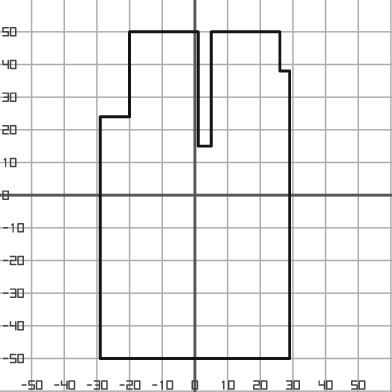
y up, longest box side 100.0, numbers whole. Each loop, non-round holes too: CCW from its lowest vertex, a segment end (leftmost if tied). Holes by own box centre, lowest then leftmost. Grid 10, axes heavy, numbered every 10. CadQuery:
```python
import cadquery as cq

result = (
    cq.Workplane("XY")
    .moveTo(-29.0, -50.0)
    .lineTo(29.0, -50.0)
    .lineTo(29.0, 38.0)
    .lineTo(26.0, 38.0)
    .lineTo(26.0, 50.0)
    .lineTo(5.0, 50.0)
    .lineTo(5.0, 15.0)
    .lineTo(1.0, 15.0)
    .lineTo(1.0, 50.0)
    .lineTo(-20.0, 50.0)
    .lineTo(-20.0, 24.0)
    .lineTo(-29.0, 24.0)
    .close()
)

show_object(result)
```